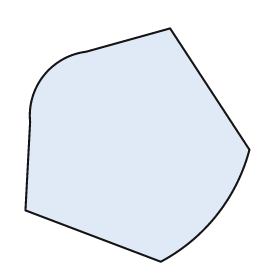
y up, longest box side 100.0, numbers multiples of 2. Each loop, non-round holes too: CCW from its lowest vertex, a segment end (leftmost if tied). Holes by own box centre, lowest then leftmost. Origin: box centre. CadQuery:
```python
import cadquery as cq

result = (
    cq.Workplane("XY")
    .moveTo(10.0, -50.0)
    .threePointArc((34.0, -30.0), (48.0, -2.0))
    .lineTo(14.0, 50.0)
    .lineTo(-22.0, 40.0)
    .threePointArc((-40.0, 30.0), (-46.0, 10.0))
    .lineTo(-48.0, -28.0)
    .close()
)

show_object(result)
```